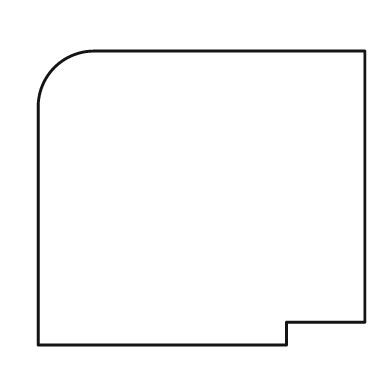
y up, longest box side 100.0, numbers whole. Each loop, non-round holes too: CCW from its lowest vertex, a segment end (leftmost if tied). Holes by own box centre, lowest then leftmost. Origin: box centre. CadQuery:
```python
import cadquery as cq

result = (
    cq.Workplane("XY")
    .moveTo(-50.0, -45.0)
    .lineTo(26.0, -45.0)
    .lineTo(26.0, -38.0)
    .lineTo(50.0, -38.0)
    .lineTo(50.0, 45.0)
    .lineTo(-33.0, 45.0)
    .threePointArc((-45.0, 40.0), (-50.0, 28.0))
    .close()
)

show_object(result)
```